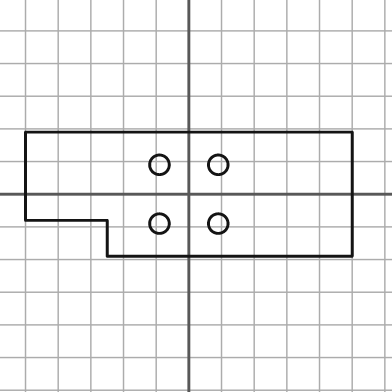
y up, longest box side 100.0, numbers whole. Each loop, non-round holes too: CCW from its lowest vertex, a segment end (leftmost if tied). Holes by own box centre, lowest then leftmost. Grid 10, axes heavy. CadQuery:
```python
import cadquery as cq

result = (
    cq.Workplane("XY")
    .moveTo(-25.0, -19.0)
    .lineTo(50.0, -19.0)
    .lineTo(50.0, 19.0)
    .lineTo(-50.0, 19.0)
    .lineTo(-50.0, -8.0)
    .lineTo(-25.0, -8.0)
    .close()
    .moveTo(-9.0, -9.0)
    .circle(3.0)
    .moveTo(9.0, -9.0)
    .circle(3.0)
    .moveTo(-9.0, 9.0)
    .circle(3.0)
    .moveTo(9.0, 9.0)
    .circle(3.0)
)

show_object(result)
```